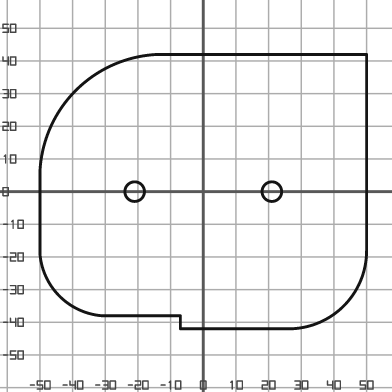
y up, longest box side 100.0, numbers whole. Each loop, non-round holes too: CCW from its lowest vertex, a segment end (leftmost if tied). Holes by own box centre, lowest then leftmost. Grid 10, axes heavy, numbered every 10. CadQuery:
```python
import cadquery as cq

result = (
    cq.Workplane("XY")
    .moveTo(-7.0, -42.0)
    .lineTo(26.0, -42.0)
    .threePointArc((43.0, -35.0), (50.0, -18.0))
    .lineTo(50.0, 42.0)
    .lineTo(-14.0, 42.0)
    .threePointArc((-39.0, 31.0), (-50.0, 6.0))
    .lineTo(-50.0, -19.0)
    .threePointArc((-44.0, -32.0), (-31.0, -38.0))
    .lineTo(-7.0, -38.0)
    .close()
    .moveTo(-21.0, 0.0)
    .circle(3.0)
    .moveTo(21.0, 0.0)
    .circle(3.0)
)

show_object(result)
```